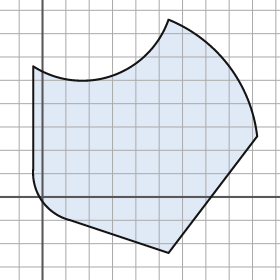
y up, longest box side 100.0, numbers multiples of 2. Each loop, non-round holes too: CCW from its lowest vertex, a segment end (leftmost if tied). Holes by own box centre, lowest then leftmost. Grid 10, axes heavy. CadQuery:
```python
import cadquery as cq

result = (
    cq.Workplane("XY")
    .moveTo(54.0, -24.0)
    .lineTo(92.0, 26.0)
    .threePointArc((80.0, 56.0), (54.0, 76.0))
    .threePointArc((30.0, 52.0), (-4.0, 56.0))
    .lineTo(-4.0, 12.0)
    .threePointArc((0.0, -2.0), (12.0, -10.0))
    .close()
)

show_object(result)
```